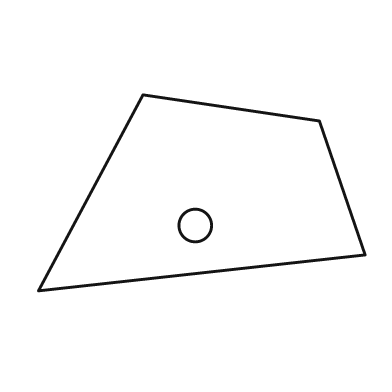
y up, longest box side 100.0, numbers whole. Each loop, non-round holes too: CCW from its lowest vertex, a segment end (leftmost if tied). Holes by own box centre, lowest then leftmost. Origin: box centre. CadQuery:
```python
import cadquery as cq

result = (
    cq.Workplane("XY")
    .moveTo(-50.0, -30.0)
    .lineTo(50.0, -19.0)
    .lineTo(36.0, 22.0)
    .lineTo(-18.0, 30.0)
    .close()
    .moveTo(-2.0, -10.0)
    .circle(5.0)
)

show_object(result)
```